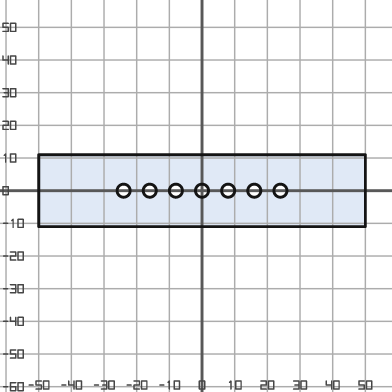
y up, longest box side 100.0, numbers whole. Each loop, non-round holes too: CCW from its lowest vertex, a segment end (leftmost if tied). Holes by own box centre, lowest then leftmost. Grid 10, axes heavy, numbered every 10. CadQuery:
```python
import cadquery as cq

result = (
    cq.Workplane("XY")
    .moveTo(-50.0, -11.0)
    .lineTo(50.0, -11.0)
    .lineTo(50.0, 11.0)
    .lineTo(-50.0, 11.0)
    .close()
    .moveTo(-24.0, 0.0)
    .circle(2.0)
    .moveTo(-16.0, 0.0)
    .circle(2.0)
    .moveTo(-8.0, 0.0)
    .circle(2.0)
    .moveTo(0.0, 0.0)
    .circle(2.0)
    .moveTo(8.0, 0.0)
    .circle(2.0)
    .moveTo(16.0, 0.0)
    .circle(2.0)
    .moveTo(24.0, 0.0)
    .circle(2.0)
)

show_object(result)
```